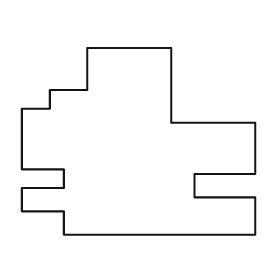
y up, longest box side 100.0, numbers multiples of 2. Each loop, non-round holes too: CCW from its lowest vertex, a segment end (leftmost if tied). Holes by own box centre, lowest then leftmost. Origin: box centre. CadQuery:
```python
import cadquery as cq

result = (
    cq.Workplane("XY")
    .moveTo(-32.0, -40.0)
    .lineTo(50.0, -40.0)
    .lineTo(50.0, -24.0)
    .lineTo(24.0, -24.0)
    .lineTo(24.0, -14.0)
    .lineTo(50.0, -14.0)
    .lineTo(50.0, 8.0)
    .lineTo(14.0, 8.0)
    .lineTo(14.0, 40.0)
    .lineTo(-22.0, 40.0)
    .lineTo(-22.0, 22.0)
    .lineTo(-38.0, 22.0)
    .lineTo(-38.0, 14.0)
    .lineTo(-50.0, 14.0)
    .lineTo(-50.0, -12.0)
    .lineTo(-32.0, -12.0)
    .lineTo(-32.0, -20.0)
    .lineTo(-50.0, -20.0)
    .lineTo(-50.0, -30.0)
    .lineTo(-32.0, -30.0)
    .close()
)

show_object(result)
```